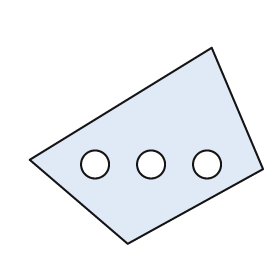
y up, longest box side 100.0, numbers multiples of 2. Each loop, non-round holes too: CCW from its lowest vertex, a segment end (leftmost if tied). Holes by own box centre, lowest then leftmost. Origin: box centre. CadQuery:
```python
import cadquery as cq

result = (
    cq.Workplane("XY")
    .moveTo(-8.0, -42.0)
    .lineTo(50.0, -10.0)
    .lineTo(28.0, 42.0)
    .lineTo(-50.0, -6.0)
    .close()
    .moveTo(-22.0, -8.0)
    .circle(6.0)
    .moveTo(2.0, -8.0)
    .circle(6.0)
    .moveTo(26.0, -8.0)
    .circle(6.0)
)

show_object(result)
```